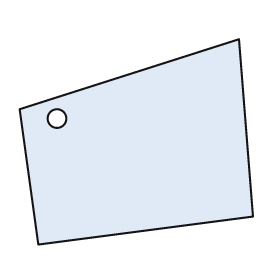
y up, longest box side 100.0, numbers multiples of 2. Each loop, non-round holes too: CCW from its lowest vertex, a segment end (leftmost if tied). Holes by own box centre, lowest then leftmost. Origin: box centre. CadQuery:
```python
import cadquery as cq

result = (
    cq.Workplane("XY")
    .moveTo(-42.0, -44.0)
    .lineTo(50.0, -32.0)
    .lineTo(44.0, 44.0)
    .lineTo(-50.0, 14.0)
    .close()
    .moveTo(-34.0, 10.0)
    .circle(4.0)
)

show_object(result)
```